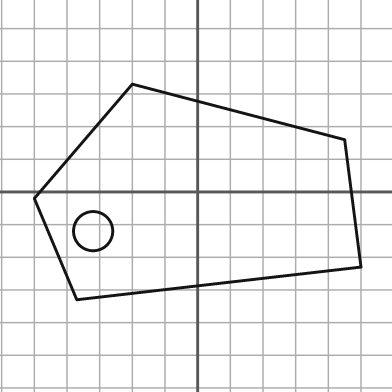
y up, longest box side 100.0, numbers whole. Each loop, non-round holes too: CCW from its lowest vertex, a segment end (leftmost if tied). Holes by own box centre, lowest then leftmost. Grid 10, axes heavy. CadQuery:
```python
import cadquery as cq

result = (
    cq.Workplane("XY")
    .moveTo(-37.0, -33.0)
    .lineTo(50.0, -23.0)
    .lineTo(45.0, 16.0)
    .lineTo(-20.0, 33.0)
    .lineTo(-50.0, -2.0)
    .close()
    .moveTo(-32.0, -12.0)
    .circle(6.0)
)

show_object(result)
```